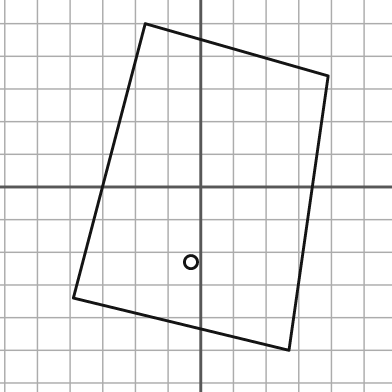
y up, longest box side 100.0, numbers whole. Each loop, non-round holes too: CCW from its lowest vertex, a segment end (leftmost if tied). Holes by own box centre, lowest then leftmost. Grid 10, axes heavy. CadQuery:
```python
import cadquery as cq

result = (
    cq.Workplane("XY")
    .moveTo(27.0, -50.0)
    .lineTo(39.0, 34.0)
    .lineTo(-17.0, 50.0)
    .lineTo(-39.0, -34.0)
    .close()
    .moveTo(-3.0, -23.0)
    .circle(2.0)
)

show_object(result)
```